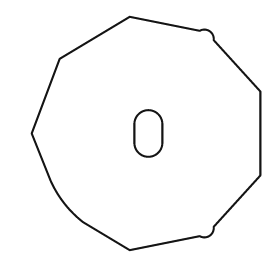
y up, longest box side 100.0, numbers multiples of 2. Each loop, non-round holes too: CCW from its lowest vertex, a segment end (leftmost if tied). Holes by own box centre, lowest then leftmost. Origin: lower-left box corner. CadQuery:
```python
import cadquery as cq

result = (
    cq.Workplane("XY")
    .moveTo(42.0, 0.0)
    .lineTo(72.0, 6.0)
    .threePointArc((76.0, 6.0), (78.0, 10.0))
    .lineTo(98.0, 32.0)
    .lineTo(98.0, 68.0)
    .lineTo(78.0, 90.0)
    .threePointArc((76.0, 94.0), (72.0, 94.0))
    .lineTo(42.0, 100.0)
    .lineTo(12.0, 82.0)
    .lineTo(0.0, 50.0)
    .lineTo(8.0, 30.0)
    .threePointArc((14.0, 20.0), (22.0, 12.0))
    .close()
    .moveTo(44.0, 46.0)
    .threePointArc((50.0, 40.0), (56.0, 46.0))
    .lineTo(56.0, 54.0)
    .threePointArc((50.0, 60.0), (44.0, 54.0))
    .close()
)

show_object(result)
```